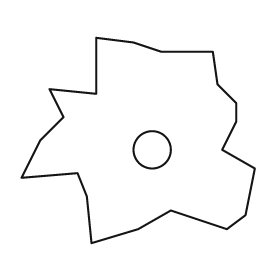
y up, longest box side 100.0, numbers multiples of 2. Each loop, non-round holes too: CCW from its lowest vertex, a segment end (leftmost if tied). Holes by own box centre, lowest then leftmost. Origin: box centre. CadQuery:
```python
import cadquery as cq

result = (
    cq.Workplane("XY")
    .moveTo(-20.0, -44.0)
    .lineTo(0.0, -38.0)
    .lineTo(14.0, -30.0)
    .lineTo(38.0, -38.0)
    .lineTo(46.0, -32.0)
    .lineTo(50.0, -12.0)
    .lineTo(36.0, -4.0)
    .lineTo(42.0, 8.0)
    .lineTo(42.0, 16.0)
    .lineTo(34.0, 24.0)
    .lineTo(32.0, 38.0)
    .lineTo(10.0, 38.0)
    .lineTo(-2.0, 42.0)
    .lineTo(-18.0, 44.0)
    .lineTo(-18.0, 20.0)
    .lineTo(-38.0, 22.0)
    .lineTo(-32.0, 10.0)
    .lineTo(-42.0, 0.0)
    .lineTo(-50.0, -16.0)
    .lineTo(-26.0, -14.0)
    .lineTo(-22.0, -24.0)
    .close()
    .moveTo(6.0, -4.0)
    .circle(8.0)
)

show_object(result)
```